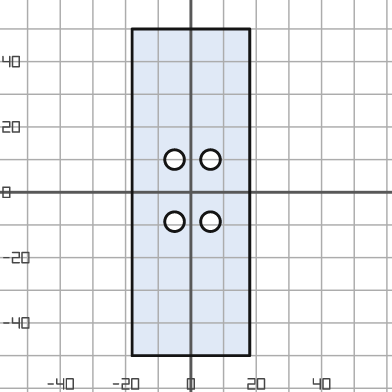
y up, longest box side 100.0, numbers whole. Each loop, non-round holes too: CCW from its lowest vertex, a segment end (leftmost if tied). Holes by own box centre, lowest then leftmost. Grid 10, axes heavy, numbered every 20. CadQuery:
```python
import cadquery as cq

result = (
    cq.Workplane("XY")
    .moveTo(-18.0, -50.0)
    .lineTo(18.0, -50.0)
    .lineTo(18.0, 50.0)
    .lineTo(-18.0, 50.0)
    .close()
    .moveTo(-5.0, -9.0)
    .circle(3.0)
    .moveTo(6.0, -9.0)
    .circle(3.0)
    .moveTo(-5.0, 10.0)
    .circle(3.0)
    .moveTo(6.0, 10.0)
    .circle(3.0)
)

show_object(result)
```